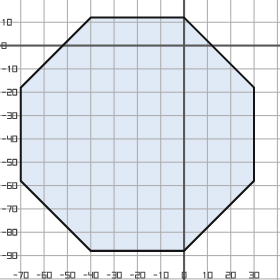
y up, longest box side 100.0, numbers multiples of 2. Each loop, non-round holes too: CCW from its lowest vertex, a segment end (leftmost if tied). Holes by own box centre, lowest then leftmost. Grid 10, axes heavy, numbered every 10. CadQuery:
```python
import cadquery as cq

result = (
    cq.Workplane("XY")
    .moveTo(-40.0, -88.0)
    .lineTo(0.0, -88.0)
    .lineTo(30.0, -58.0)
    .lineTo(30.0, -18.0)
    .lineTo(0.0, 12.0)
    .lineTo(-40.0, 12.0)
    .lineTo(-70.0, -18.0)
    .lineTo(-70.0, -58.0)
    .close()
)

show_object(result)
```